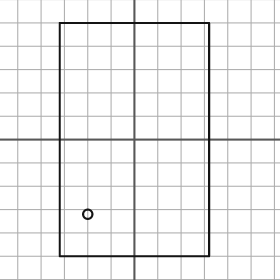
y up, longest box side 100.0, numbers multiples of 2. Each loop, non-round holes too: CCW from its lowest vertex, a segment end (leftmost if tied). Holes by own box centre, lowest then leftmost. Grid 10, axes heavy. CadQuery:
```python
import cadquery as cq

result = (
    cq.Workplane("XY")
    .moveTo(-32.0, -50.0)
    .lineTo(32.0, -50.0)
    .lineTo(32.0, 50.0)
    .lineTo(-32.0, 50.0)
    .close()
    .moveTo(-20.0, -32.0)
    .circle(2.0)
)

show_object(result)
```